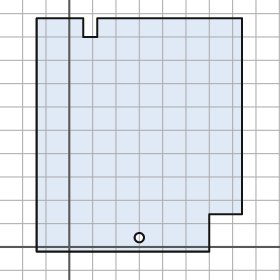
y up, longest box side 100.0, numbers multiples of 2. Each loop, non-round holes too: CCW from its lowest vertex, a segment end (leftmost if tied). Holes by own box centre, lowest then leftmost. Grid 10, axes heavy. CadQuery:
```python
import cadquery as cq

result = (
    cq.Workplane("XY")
    .moveTo(-14.0, -2.0)
    .lineTo(60.0, -2.0)
    .lineTo(60.0, 14.0)
    .lineTo(74.0, 14.0)
    .lineTo(74.0, 98.0)
    .lineTo(12.0, 98.0)
    .lineTo(12.0, 90.0)
    .lineTo(6.0, 90.0)
    .lineTo(6.0, 98.0)
    .lineTo(-14.0, 98.0)
    .close()
    .moveTo(30.0, 4.0)
    .circle(2.0)
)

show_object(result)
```